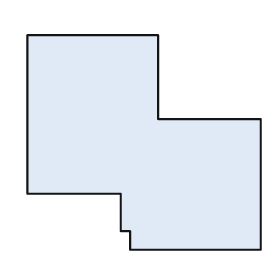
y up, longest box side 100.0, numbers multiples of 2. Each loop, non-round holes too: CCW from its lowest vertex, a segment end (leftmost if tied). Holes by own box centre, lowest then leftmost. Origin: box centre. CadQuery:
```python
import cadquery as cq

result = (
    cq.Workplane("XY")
    .moveTo(-6.0, -46.0)
    .lineTo(50.0, -46.0)
    .lineTo(50.0, 10.0)
    .lineTo(6.0, 10.0)
    .lineTo(6.0, 46.0)
    .lineTo(-50.0, 46.0)
    .lineTo(-50.0, -22.0)
    .lineTo(-10.0, -22.0)
    .lineTo(-10.0, -38.0)
    .lineTo(-6.0, -38.0)
    .close()
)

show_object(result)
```